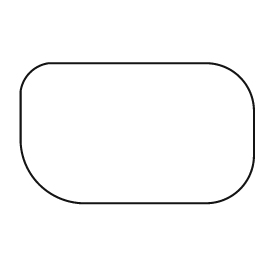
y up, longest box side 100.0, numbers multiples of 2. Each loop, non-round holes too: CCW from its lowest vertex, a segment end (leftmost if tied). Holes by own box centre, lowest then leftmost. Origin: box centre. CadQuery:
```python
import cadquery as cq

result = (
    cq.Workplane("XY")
    .moveTo(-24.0, -30.0)
    .lineTo(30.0, -30.0)
    .threePointArc((44.0, -24.0), (50.0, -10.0))
    .lineTo(50.0, 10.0)
    .threePointArc((44.0, 24.0), (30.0, 30.0))
    .lineTo(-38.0, 30.0)
    .threePointArc((-46.0, 26.0), (-50.0, 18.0))
    .lineTo(-50.0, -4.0)
    .threePointArc((-42.0, -22.0), (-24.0, -30.0))
    .close()
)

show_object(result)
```